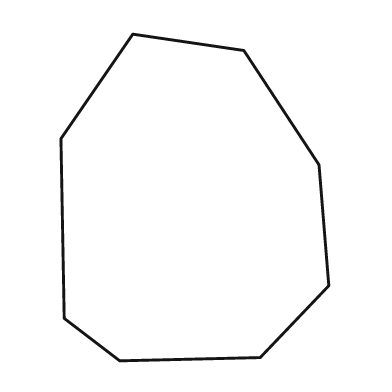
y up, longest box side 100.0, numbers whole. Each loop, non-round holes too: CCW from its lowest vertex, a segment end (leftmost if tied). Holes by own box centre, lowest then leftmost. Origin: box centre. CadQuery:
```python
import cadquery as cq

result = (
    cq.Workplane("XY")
    .moveTo(-23.0, -50.0)
    .lineTo(20.0, -49.0)
    .lineTo(41.0, -27.0)
    .lineTo(38.0, 10.0)
    .lineTo(15.0, 45.0)
    .lineTo(-19.0, 50.0)
    .lineTo(-41.0, 18.0)
    .lineTo(-40.0, -37.0)
    .close()
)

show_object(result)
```